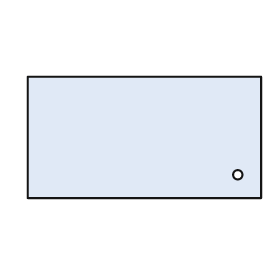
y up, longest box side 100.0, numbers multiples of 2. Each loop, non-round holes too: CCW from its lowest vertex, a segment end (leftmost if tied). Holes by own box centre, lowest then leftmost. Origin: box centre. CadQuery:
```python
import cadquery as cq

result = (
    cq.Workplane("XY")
    .moveTo(-50.0, -26.0)
    .lineTo(50.0, -26.0)
    .lineTo(50.0, 26.0)
    .lineTo(-50.0, 26.0)
    .close()
    .moveTo(40.0, -16.0)
    .circle(2.0)
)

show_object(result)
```